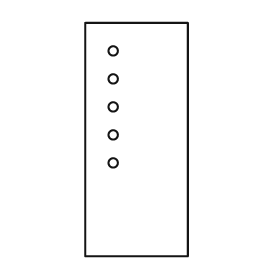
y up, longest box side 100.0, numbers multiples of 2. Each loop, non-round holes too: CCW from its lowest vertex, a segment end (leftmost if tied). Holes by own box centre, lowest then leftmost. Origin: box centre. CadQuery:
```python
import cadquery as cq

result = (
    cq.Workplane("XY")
    .moveTo(-22.0, -50.0)
    .lineTo(22.0, -50.0)
    .lineTo(22.0, 50.0)
    .lineTo(-22.0, 50.0)
    .close()
    .moveTo(-10.0, -10.0)
    .circle(2.0)
    .moveTo(-10.0, 2.0)
    .circle(2.0)
    .moveTo(-10.0, 14.0)
    .circle(2.0)
    .moveTo(-10.0, 26.0)
    .circle(2.0)
    .moveTo(-10.0, 38.0)
    .circle(2.0)
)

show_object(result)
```